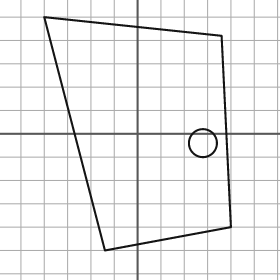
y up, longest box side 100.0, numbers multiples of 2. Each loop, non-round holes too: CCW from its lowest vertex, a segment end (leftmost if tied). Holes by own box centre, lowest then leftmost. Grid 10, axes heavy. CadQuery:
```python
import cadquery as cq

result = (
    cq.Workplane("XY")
    .moveTo(-14.0, -50.0)
    .lineTo(40.0, -40.0)
    .lineTo(36.0, 42.0)
    .lineTo(-40.0, 50.0)
    .close()
    .moveTo(28.0, -4.0)
    .circle(6.0)
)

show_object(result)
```